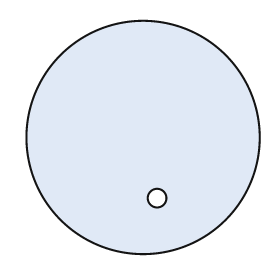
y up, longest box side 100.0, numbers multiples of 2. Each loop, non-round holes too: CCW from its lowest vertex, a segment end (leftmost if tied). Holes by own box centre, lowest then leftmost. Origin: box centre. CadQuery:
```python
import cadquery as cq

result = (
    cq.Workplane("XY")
    .moveTo(0.0, 0.0)
    .circle(50.0)
    .moveTo(6.0, -26.0)
    .circle(4.0)
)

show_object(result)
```